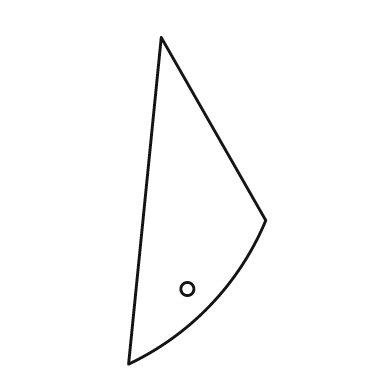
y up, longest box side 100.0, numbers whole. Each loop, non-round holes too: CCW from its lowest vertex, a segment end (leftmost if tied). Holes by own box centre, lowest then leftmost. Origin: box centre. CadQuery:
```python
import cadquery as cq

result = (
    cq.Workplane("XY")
    .moveTo(-21.0, -50.0)
    .threePointArc((4.0, -32.0), (21.0, -6.0))
    .lineTo(-11.0, 50.0)
    .close()
    .moveTo(-3.0, -27.0)
    .circle(2.0)
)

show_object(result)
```